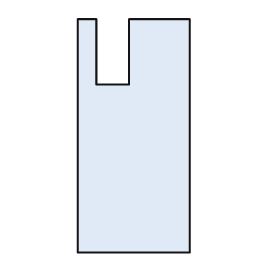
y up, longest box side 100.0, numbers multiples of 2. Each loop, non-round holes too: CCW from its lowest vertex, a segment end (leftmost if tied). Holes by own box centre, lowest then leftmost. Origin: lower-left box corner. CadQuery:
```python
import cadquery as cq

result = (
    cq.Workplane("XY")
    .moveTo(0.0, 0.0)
    .lineTo(48.0, 0.0)
    .lineTo(48.0, 100.0)
    .lineTo(22.0, 100.0)
    .lineTo(22.0, 72.0)
    .lineTo(8.0, 72.0)
    .lineTo(8.0, 100.0)
    .lineTo(0.0, 100.0)
    .close()
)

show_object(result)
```